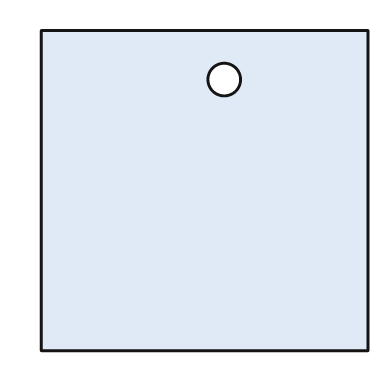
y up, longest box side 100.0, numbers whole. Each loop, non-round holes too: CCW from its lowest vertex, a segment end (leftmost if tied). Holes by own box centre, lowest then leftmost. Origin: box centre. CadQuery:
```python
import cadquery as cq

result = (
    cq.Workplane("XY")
    .moveTo(-50.0, -49.0)
    .lineTo(50.0, -49.0)
    .lineTo(50.0, 49.0)
    .lineTo(-50.0, 49.0)
    .close()
    .moveTo(6.0, 34.0)
    .circle(5.0)
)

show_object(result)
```